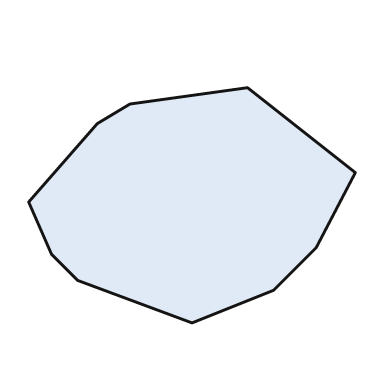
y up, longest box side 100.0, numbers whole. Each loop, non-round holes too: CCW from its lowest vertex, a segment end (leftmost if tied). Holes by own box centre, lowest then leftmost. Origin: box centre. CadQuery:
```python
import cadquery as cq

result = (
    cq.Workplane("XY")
    .moveTo(0.0, -36.0)
    .lineTo(25.0, -26.0)
    .lineTo(38.0, -13.0)
    .lineTo(50.0, 10.0)
    .lineTo(17.0, 36.0)
    .lineTo(-19.0, 31.0)
    .lineTo(-29.0, 25.0)
    .lineTo(-50.0, 1.0)
    .lineTo(-43.0, -15.0)
    .lineTo(-35.0, -23.0)
    .close()
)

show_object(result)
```